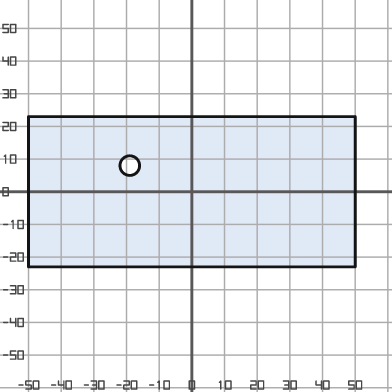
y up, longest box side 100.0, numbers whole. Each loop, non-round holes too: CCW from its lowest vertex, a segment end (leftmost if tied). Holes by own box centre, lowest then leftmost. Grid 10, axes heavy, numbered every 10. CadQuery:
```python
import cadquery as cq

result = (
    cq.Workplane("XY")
    .moveTo(-50.0, -23.0)
    .lineTo(50.0, -23.0)
    .lineTo(50.0, 23.0)
    .lineTo(-50.0, 23.0)
    .close()
    .moveTo(-19.0, 8.0)
    .circle(3.0)
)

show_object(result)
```